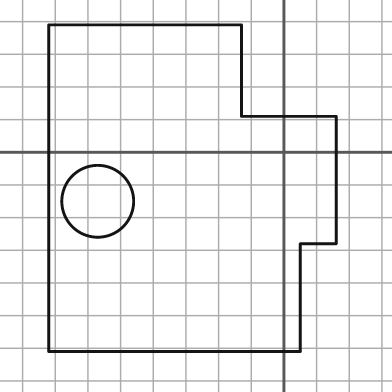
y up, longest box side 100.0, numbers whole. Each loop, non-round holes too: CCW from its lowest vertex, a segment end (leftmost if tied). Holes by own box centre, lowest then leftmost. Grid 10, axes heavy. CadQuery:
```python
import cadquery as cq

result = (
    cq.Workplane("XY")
    .moveTo(-72.0, -61.0)
    .lineTo(5.0, -61.0)
    .lineTo(5.0, -28.0)
    .lineTo(16.0, -28.0)
    .lineTo(16.0, 11.0)
    .lineTo(-13.0, 11.0)
    .lineTo(-13.0, 39.0)
    .lineTo(-72.0, 39.0)
    .close()
    .moveTo(-57.0, -15.0)
    .circle(11.0)
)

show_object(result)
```